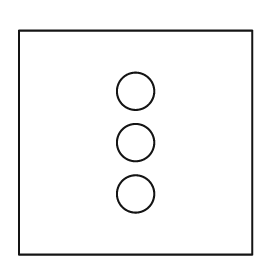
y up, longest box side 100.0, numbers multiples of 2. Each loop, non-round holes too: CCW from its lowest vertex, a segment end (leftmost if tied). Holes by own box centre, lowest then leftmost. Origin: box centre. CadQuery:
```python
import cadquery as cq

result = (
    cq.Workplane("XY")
    .moveTo(-50.0, -48.0)
    .lineTo(50.0, -48.0)
    .lineTo(50.0, 48.0)
    .lineTo(-50.0, 48.0)
    .close()
    .moveTo(0.0, -22.0)
    .circle(8.0)
    .moveTo(0.0, 0.0)
    .circle(8.0)
    .moveTo(0.0, 22.0)
    .circle(8.0)
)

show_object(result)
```